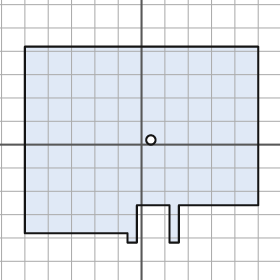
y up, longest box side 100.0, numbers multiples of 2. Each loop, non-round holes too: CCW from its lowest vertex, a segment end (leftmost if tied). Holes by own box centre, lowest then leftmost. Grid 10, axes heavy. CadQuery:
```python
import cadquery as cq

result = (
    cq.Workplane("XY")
    .moveTo(-6.0, -42.0)
    .lineTo(-2.0, -42.0)
    .lineTo(-2.0, -26.0)
    .lineTo(12.0, -26.0)
    .lineTo(12.0, -42.0)
    .lineTo(16.0, -42.0)
    .lineTo(16.0, -26.0)
    .lineTo(50.0, -26.0)
    .lineTo(50.0, 42.0)
    .lineTo(-50.0, 42.0)
    .lineTo(-50.0, -38.0)
    .lineTo(-6.0, -38.0)
    .close()
    .moveTo(4.0, 2.0)
    .circle(2.0)
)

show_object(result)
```